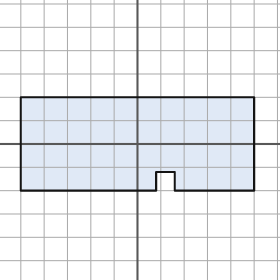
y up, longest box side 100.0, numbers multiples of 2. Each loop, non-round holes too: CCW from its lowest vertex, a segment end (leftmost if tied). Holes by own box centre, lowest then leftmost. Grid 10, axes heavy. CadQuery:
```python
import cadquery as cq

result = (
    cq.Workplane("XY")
    .moveTo(-50.0, -20.0)
    .lineTo(8.0, -20.0)
    .lineTo(8.0, -12.0)
    .lineTo(16.0, -12.0)
    .lineTo(16.0, -20.0)
    .lineTo(50.0, -20.0)
    .lineTo(50.0, 20.0)
    .lineTo(-50.0, 20.0)
    .close()
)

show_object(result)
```